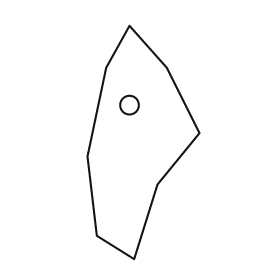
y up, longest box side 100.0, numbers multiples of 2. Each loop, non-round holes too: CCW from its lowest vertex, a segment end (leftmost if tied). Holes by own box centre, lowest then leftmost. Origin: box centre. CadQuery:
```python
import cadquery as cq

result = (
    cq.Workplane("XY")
    .moveTo(-4.0, -50.0)
    .lineTo(6.0, -18.0)
    .lineTo(24.0, 4.0)
    .lineTo(10.0, 32.0)
    .lineTo(-6.0, 50.0)
    .lineTo(-16.0, 32.0)
    .lineTo(-24.0, -6.0)
    .lineTo(-20.0, -40.0)
    .close()
    .moveTo(-6.0, 16.0)
    .circle(4.0)
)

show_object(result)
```